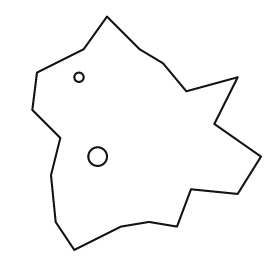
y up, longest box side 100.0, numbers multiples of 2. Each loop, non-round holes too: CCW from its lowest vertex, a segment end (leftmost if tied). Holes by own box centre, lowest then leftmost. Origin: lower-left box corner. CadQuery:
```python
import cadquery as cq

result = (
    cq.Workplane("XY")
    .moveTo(18.0, 0.0)
    .lineTo(38.0, 10.0)
    .lineTo(50.0, 12.0)
    .lineTo(62.0, 10.0)
    .lineTo(68.0, 26.0)
    .lineTo(88.0, 24.0)
    .lineTo(98.0, 40.0)
    .lineTo(78.0, 54.0)
    .lineTo(88.0, 74.0)
    .lineTo(66.0, 68.0)
    .lineTo(56.0, 80.0)
    .lineTo(46.0, 86.0)
    .lineTo(32.0, 100.0)
    .lineTo(22.0, 86.0)
    .lineTo(2.0, 76.0)
    .lineTo(0.0, 60.0)
    .lineTo(12.0, 48.0)
    .lineTo(8.0, 32.0)
    .lineTo(10.0, 12.0)
    .close()
    .moveTo(28.0, 40.0)
    .circle(4.0)
    .moveTo(20.0, 74.0)
    .circle(2.0)
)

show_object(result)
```